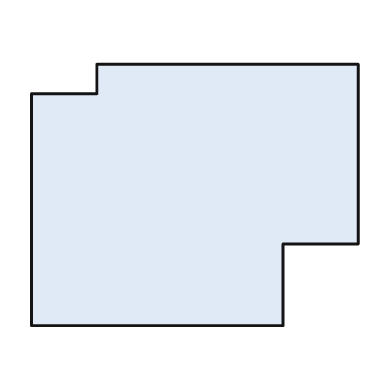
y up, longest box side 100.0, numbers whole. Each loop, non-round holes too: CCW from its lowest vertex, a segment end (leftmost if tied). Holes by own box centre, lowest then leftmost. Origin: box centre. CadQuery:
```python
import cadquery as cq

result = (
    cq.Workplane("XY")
    .moveTo(-50.0, -40.0)
    .lineTo(27.0, -40.0)
    .lineTo(27.0, -15.0)
    .lineTo(50.0, -15.0)
    .lineTo(50.0, 40.0)
    .lineTo(-30.0, 40.0)
    .lineTo(-30.0, 31.0)
    .lineTo(-50.0, 31.0)
    .close()
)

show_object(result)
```